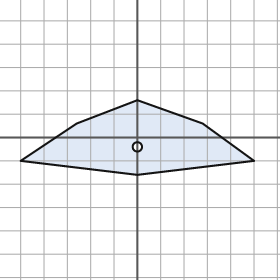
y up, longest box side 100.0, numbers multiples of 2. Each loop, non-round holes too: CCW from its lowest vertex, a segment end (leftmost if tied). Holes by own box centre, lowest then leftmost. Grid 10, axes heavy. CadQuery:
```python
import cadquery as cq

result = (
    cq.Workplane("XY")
    .moveTo(0.0, -16.0)
    .lineTo(50.0, -10.0)
    .lineTo(28.0, 6.0)
    .lineTo(0.0, 16.0)
    .lineTo(-26.0, 6.0)
    .lineTo(-50.0, -10.0)
    .close()
    .moveTo(0.0, -4.0)
    .circle(2.0)
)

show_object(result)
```